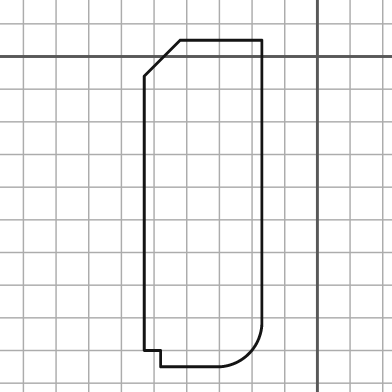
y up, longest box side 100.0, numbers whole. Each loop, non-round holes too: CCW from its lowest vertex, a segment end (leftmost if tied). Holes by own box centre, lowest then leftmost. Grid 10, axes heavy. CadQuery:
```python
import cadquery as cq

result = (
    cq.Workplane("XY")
    .moveTo(-48.0, -95.0)
    .lineTo(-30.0, -95.0)
    .threePointArc((-21.0, -91.0), (-17.0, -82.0))
    .lineTo(-17.0, 5.0)
    .lineTo(-42.0, 5.0)
    .lineTo(-53.0, -6.0)
    .lineTo(-53.0, -90.0)
    .lineTo(-48.0, -90.0)
    .close()
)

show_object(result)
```